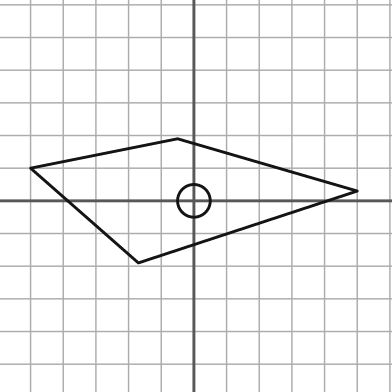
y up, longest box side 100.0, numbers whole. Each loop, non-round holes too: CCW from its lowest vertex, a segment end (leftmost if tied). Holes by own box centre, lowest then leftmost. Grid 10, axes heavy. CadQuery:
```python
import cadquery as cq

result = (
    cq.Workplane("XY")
    .moveTo(-17.0, -19.0)
    .lineTo(50.0, 3.0)
    .lineTo(-5.0, 19.0)
    .lineTo(-50.0, 10.0)
    .close()
    .moveTo(0.0, 0.0)
    .circle(5.0)
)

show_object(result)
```